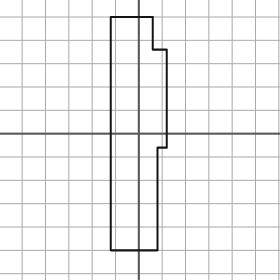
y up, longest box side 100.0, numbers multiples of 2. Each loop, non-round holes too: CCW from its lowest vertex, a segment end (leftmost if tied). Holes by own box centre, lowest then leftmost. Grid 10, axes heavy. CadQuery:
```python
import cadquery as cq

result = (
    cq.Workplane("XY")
    .moveTo(-12.0, -50.0)
    .lineTo(8.0, -50.0)
    .lineTo(8.0, -6.0)
    .lineTo(12.0, -6.0)
    .lineTo(12.0, 36.0)
    .lineTo(6.0, 36.0)
    .lineTo(6.0, 50.0)
    .lineTo(-12.0, 50.0)
    .close()
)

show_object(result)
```